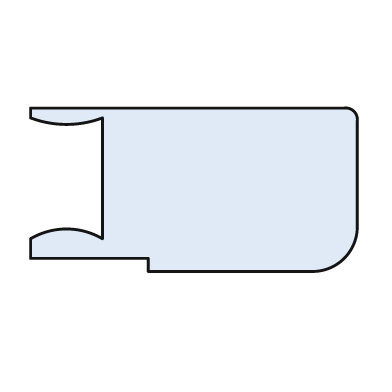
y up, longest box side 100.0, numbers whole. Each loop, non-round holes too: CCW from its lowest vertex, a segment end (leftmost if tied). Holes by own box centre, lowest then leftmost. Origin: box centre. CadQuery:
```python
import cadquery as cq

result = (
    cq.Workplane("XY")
    .moveTo(-14.0, -25.0)
    .lineTo(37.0, -25.0)
    .threePointArc((46.0, -21.0), (50.0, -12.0))
    .lineTo(50.0, 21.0)
    .threePointArc((49.0, 24.0), (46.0, 25.0))
    .lineTo(-50.0, 25.0)
    .lineTo(-50.0, 22.0)
    .threePointArc((-39.0, 20.0), (-28.0, 22.0))
    .lineTo(-28.0, -15.0)
    .threePointArc((-39.0, -12.0), (-50.0, -15.0))
    .lineTo(-50.0, -21.0)
    .lineTo(-14.0, -21.0)
    .close()
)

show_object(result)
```